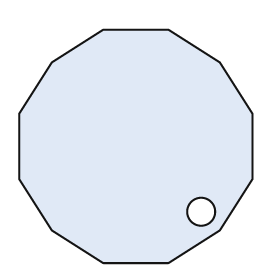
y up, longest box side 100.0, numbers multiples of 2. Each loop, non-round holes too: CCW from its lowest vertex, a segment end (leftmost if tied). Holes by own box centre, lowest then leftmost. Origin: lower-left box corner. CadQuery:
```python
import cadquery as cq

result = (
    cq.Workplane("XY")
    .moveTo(36.0, 0.0)
    .lineTo(64.0, 0.0)
    .lineTo(86.0, 14.0)
    .lineTo(100.0, 36.0)
    .lineTo(100.0, 64.0)
    .lineTo(86.0, 86.0)
    .lineTo(64.0, 100.0)
    .lineTo(36.0, 100.0)
    .lineTo(14.0, 86.0)
    .lineTo(0.0, 64.0)
    .lineTo(0.0, 36.0)
    .lineTo(14.0, 14.0)
    .close()
    .moveTo(78.0, 22.0)
    .circle(6.0)
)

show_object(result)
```